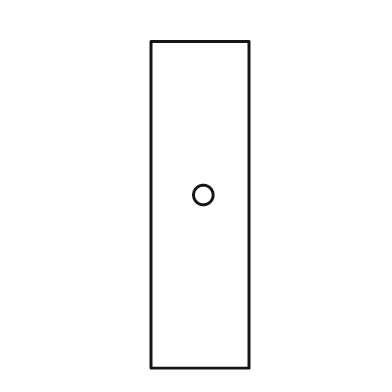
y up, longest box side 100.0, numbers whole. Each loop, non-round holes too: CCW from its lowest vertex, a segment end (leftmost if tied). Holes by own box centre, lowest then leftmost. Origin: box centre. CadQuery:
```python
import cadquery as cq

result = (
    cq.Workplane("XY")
    .moveTo(-15.0, -50.0)
    .lineTo(15.0, -50.0)
    .lineTo(15.0, 50.0)
    .lineTo(-15.0, 50.0)
    .close()
    .moveTo(1.0, 3.0)
    .circle(3.0)
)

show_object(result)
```